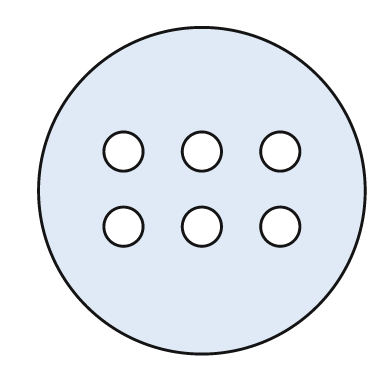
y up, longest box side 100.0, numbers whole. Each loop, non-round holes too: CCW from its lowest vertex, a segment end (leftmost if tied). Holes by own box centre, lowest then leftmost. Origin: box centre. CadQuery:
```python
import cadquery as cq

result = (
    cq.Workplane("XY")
    .moveTo(0.0, 0.0)
    .circle(50.0)
    .moveTo(-24.0, -11.0)
    .circle(6.0)
    .moveTo(0.0, -11.0)
    .circle(6.0)
    .moveTo(24.0, -11.0)
    .circle(6.0)
    .moveTo(-24.0, 12.0)
    .circle(6.0)
    .moveTo(0.0, 12.0)
    .circle(6.0)
    .moveTo(24.0, 12.0)
    .circle(6.0)
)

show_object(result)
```